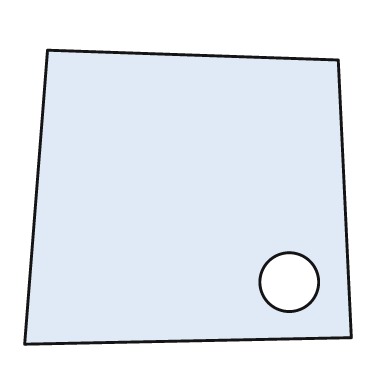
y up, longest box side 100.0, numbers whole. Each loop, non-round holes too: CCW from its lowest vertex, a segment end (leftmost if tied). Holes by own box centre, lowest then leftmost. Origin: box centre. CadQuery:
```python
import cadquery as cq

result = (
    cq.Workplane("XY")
    .moveTo(-50.0, -45.0)
    .lineTo(50.0, -43.0)
    .lineTo(46.0, 42.0)
    .lineTo(-43.0, 45.0)
    .close()
    .moveTo(31.0, -26.0)
    .circle(9.0)
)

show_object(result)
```